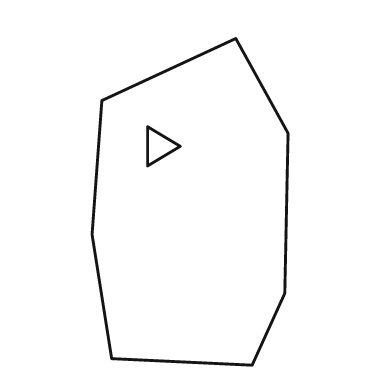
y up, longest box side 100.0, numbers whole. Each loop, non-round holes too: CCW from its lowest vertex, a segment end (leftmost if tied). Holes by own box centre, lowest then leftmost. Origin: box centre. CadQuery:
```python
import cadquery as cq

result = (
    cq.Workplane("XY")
    .moveTo(19.0, -50.0)
    .lineTo(29.0, -28.0)
    .lineTo(30.0, 21.0)
    .lineTo(14.0, 50.0)
    .lineTo(-27.0, 31.0)
    .lineTo(-30.0, -10.0)
    .lineTo(-24.0, -48.0)
    .close()
    .moveTo(-13.0, 11.0)
    .lineTo(-3.0, 17.0)
    .lineTo(-13.0, 23.0)
    .close()
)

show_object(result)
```